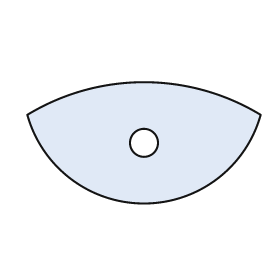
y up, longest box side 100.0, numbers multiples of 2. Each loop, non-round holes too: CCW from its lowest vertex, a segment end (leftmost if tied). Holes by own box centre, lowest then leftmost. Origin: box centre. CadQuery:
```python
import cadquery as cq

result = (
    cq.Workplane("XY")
    .moveTo(-50.0, 12.0)
    .threePointArc((0.0, -26.0), (50.0, 12.0))
    .threePointArc((0.0, 26.0), (-50.0, 12.0))
    .close()
    .moveTo(0.0, 0.0)
    .circle(6.0)
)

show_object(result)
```